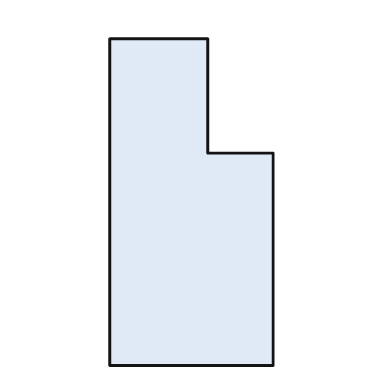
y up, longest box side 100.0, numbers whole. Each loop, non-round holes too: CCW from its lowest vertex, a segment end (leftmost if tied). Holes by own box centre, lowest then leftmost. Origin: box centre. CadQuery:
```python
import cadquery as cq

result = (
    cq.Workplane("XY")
    .moveTo(-25.0, -50.0)
    .lineTo(25.0, -50.0)
    .lineTo(25.0, 15.0)
    .lineTo(5.0, 15.0)
    .lineTo(5.0, 50.0)
    .lineTo(-25.0, 50.0)
    .close()
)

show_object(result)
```